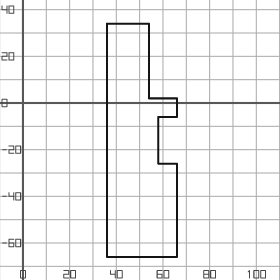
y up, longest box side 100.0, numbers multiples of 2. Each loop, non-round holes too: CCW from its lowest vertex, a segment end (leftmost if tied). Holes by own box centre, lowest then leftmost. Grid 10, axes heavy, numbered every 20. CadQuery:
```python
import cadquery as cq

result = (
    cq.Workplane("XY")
    .moveTo(36.0, -66.0)
    .lineTo(66.0, -66.0)
    .lineTo(66.0, -26.0)
    .lineTo(58.0, -26.0)
    .lineTo(58.0, -6.0)
    .lineTo(66.0, -6.0)
    .lineTo(66.0, 2.0)
    .lineTo(54.0, 2.0)
    .lineTo(54.0, 34.0)
    .lineTo(36.0, 34.0)
    .close()
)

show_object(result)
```